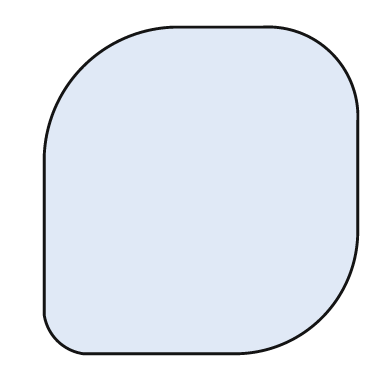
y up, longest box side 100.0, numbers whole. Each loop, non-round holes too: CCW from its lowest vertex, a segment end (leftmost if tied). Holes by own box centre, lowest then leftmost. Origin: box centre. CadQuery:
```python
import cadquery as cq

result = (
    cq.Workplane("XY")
    .moveTo(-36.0, -50.0)
    .lineTo(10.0, -50.0)
    .threePointArc((37.0, -39.0), (48.0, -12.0))
    .lineTo(48.0, 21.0)
    .threePointArc((40.0, 42.0), (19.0, 50.0))
    .lineTo(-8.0, 50.0)
    .threePointArc((-36.0, 38.0), (-48.0, 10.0))
    .lineTo(-48.0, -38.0)
    .threePointArc((-44.0, -46.0), (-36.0, -50.0))
    .close()
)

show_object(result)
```